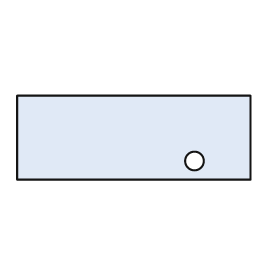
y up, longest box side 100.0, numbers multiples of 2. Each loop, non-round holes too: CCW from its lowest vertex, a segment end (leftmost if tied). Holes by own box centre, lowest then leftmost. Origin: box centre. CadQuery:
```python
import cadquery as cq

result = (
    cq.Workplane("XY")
    .moveTo(-50.0, -18.0)
    .lineTo(50.0, -18.0)
    .lineTo(50.0, 18.0)
    .lineTo(-50.0, 18.0)
    .close()
    .moveTo(26.0, -10.0)
    .circle(4.0)
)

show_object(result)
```